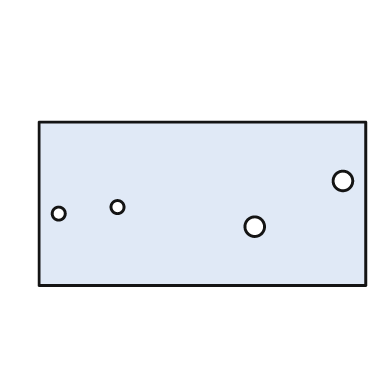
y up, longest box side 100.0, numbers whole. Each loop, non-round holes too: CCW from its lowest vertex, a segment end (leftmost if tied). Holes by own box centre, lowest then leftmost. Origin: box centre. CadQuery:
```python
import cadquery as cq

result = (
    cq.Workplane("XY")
    .moveTo(-50.0, -25.0)
    .lineTo(50.0, -25.0)
    .lineTo(50.0, 25.0)
    .lineTo(-50.0, 25.0)
    .close()
    .moveTo(16.0, -7.0)
    .circle(3.0)
    .moveTo(-44.0, -3.0)
    .circle(2.0)
    .moveTo(-26.0, -1.0)
    .circle(2.0)
    .moveTo(43.0, 7.0)
    .circle(3.0)
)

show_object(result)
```